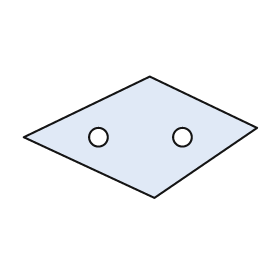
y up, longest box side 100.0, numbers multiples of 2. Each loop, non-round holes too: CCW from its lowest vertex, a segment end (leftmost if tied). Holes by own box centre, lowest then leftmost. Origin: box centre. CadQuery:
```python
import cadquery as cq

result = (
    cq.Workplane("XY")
    .moveTo(6.0, -26.0)
    .lineTo(50.0, 4.0)
    .lineTo(4.0, 26.0)
    .lineTo(-50.0, 0.0)
    .close()
    .moveTo(-18.0, 0.0)
    .circle(4.0)
    .moveTo(18.0, 0.0)
    .circle(4.0)
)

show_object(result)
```